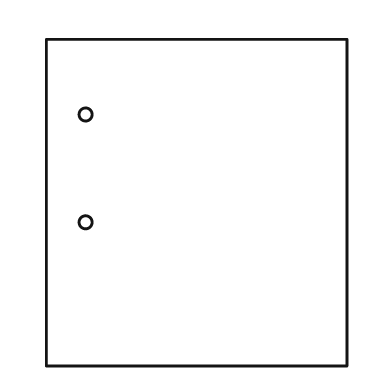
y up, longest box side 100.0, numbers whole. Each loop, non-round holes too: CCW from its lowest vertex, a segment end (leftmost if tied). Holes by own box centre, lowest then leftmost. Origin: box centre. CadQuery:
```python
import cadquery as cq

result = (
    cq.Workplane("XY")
    .moveTo(-46.0, -50.0)
    .lineTo(46.0, -50.0)
    .lineTo(46.0, 50.0)
    .lineTo(-46.0, 50.0)
    .close()
    .moveTo(-34.0, -6.0)
    .circle(2.0)
    .moveTo(-34.0, 27.0)
    .circle(2.0)
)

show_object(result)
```